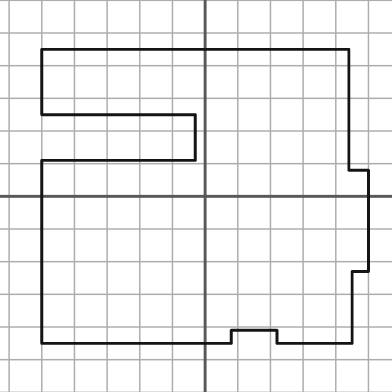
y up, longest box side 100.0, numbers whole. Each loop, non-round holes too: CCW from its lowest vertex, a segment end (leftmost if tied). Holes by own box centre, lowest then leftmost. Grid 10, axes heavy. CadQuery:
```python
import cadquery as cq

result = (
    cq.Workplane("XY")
    .moveTo(-50.0, -45.0)
    .lineTo(8.0, -45.0)
    .lineTo(8.0, -41.0)
    .lineTo(22.0, -41.0)
    .lineTo(22.0, -45.0)
    .lineTo(45.0, -45.0)
    .lineTo(45.0, -23.0)
    .lineTo(50.0, -23.0)
    .lineTo(50.0, 8.0)
    .lineTo(44.0, 8.0)
    .lineTo(44.0, 45.0)
    .lineTo(-50.0, 45.0)
    .lineTo(-50.0, 25.0)
    .lineTo(-3.0, 25.0)
    .lineTo(-3.0, 11.0)
    .lineTo(-50.0, 11.0)
    .close()
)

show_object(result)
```